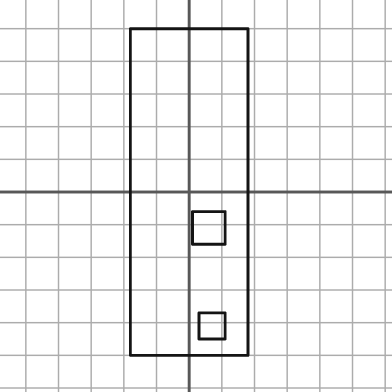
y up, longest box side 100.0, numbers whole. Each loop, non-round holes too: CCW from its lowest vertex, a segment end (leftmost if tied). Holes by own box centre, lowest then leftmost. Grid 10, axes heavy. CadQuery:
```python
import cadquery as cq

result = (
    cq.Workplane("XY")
    .moveTo(-18.0, -50.0)
    .lineTo(18.0, -50.0)
    .lineTo(18.0, 50.0)
    .lineTo(-18.0, 50.0)
    .close()
    .moveTo(3.0, -45.0)
    .lineTo(11.0, -45.0)
    .lineTo(11.0, -37.0)
    .lineTo(3.0, -37.0)
    .close()
    .moveTo(1.0, -16.0)
    .lineTo(11.0, -16.0)
    .lineTo(11.0, -6.0)
    .lineTo(1.0, -6.0)
    .close()
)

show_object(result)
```